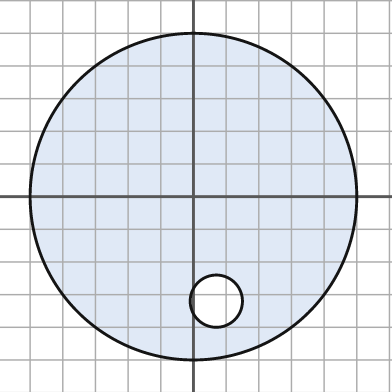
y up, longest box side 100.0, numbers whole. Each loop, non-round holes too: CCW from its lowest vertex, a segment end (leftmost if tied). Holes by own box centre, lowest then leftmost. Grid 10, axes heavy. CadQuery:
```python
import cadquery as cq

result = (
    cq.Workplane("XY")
    .moveTo(0.0, 0.0)
    .circle(50.0)
    .moveTo(7.0, -32.0)
    .circle(8.0)
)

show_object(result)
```